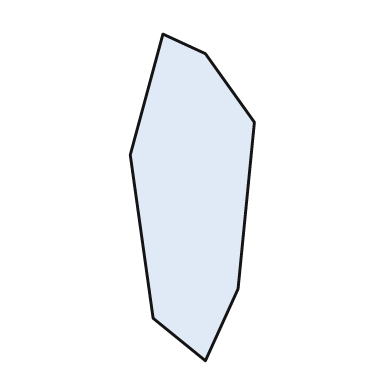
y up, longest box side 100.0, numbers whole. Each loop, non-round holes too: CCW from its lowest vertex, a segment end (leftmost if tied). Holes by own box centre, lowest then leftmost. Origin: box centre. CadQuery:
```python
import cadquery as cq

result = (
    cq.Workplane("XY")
    .moveTo(4.0, -50.0)
    .lineTo(14.0, -28.0)
    .lineTo(19.0, 23.0)
    .lineTo(4.0, 44.0)
    .lineTo(-9.0, 50.0)
    .lineTo(-19.0, 13.0)
    .lineTo(-12.0, -37.0)
    .close()
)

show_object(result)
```